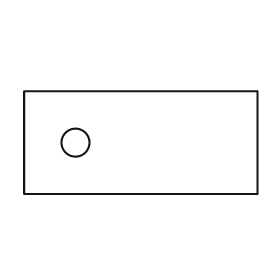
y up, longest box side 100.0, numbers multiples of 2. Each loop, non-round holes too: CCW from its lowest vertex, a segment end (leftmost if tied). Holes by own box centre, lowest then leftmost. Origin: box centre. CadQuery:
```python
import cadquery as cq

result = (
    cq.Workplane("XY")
    .moveTo(-50.0, -22.0)
    .lineTo(50.0, -22.0)
    .lineTo(50.0, 22.0)
    .lineTo(-50.0, 22.0)
    .close()
    .moveTo(-28.0, 0.0)
    .circle(6.0)
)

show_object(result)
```